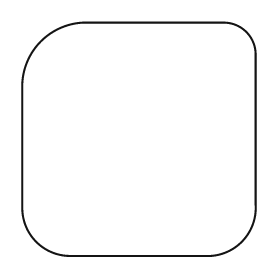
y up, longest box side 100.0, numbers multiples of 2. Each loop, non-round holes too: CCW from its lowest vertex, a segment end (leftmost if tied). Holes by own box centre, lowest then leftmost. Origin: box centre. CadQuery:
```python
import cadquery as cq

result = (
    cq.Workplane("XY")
    .moveTo(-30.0, -50.0)
    .lineTo(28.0, -50.0)
    .threePointArc((44.0, -44.0), (50.0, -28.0))
    .lineTo(50.0, 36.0)
    .threePointArc((46.0, 46.0), (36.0, 50.0))
    .lineTo(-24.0, 50.0)
    .threePointArc((-42.0, 42.0), (-50.0, 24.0))
    .lineTo(-50.0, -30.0)
    .threePointArc((-44.0, -44.0), (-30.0, -50.0))
    .close()
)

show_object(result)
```